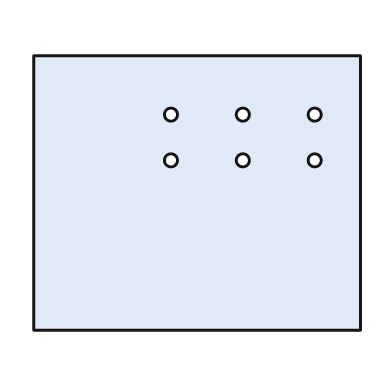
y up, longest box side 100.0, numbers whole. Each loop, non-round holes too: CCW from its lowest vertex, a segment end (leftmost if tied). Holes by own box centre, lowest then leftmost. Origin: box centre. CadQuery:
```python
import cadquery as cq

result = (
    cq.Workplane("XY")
    .moveTo(-50.0, -42.0)
    .lineTo(50.0, -42.0)
    .lineTo(50.0, 42.0)
    .lineTo(-50.0, 42.0)
    .close()
    .moveTo(-8.0, 10.0)
    .circle(2.0)
    .moveTo(14.0, 10.0)
    .circle(2.0)
    .moveTo(36.0, 10.0)
    .circle(2.0)
    .moveTo(-8.0, 24.0)
    .circle(2.0)
    .moveTo(14.0, 24.0)
    .circle(2.0)
    .moveTo(36.0, 24.0)
    .circle(2.0)
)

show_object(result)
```